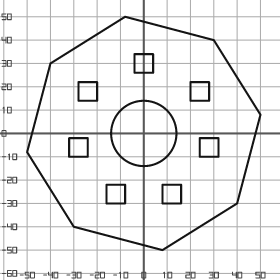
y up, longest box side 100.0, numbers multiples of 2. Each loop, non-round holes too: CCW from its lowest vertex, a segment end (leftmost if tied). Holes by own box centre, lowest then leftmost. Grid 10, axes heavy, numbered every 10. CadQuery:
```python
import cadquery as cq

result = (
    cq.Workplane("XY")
    .moveTo(8.0, -50.0)
    .lineTo(40.0, -30.0)
    .lineTo(50.0, 8.0)
    .lineTo(30.0, 40.0)
    .lineTo(-8.0, 50.0)
    .lineTo(-40.0, 30.0)
    .lineTo(-50.0, -8.0)
    .lineTo(-30.0, -40.0)
    .close()
    .moveTo(-16.0, -30.0)
    .lineTo(-8.0, -30.0)
    .lineTo(-8.0, -22.0)
    .lineTo(-16.0, -22.0)
    .close()
    .moveTo(8.0, -30.0)
    .lineTo(16.0, -30.0)
    .lineTo(16.0, -22.0)
    .lineTo(8.0, -22.0)
    .close()
    .moveTo(-32.0, -10.0)
    .lineTo(-24.0, -10.0)
    .lineTo(-24.0, -2.0)
    .lineTo(-32.0, -2.0)
    .close()
    .moveTo(24.0, -10.0)
    .lineTo(32.0, -10.0)
    .lineTo(32.0, -2.0)
    .lineTo(24.0, -2.0)
    .close()
    .moveTo(0.0, 0.0)
    .circle(14.0)
    .moveTo(-28.0, 14.0)
    .lineTo(-20.0, 14.0)
    .lineTo(-20.0, 22.0)
    .lineTo(-28.0, 22.0)
    .close()
    .moveTo(20.0, 14.0)
    .lineTo(28.0, 14.0)
    .lineTo(28.0, 22.0)
    .lineTo(20.0, 22.0)
    .close()
    .moveTo(-4.0, 26.0)
    .lineTo(4.0, 26.0)
    .lineTo(4.0, 34.0)
    .lineTo(-4.0, 34.0)
    .close()
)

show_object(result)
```